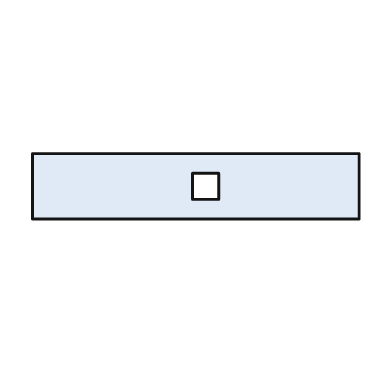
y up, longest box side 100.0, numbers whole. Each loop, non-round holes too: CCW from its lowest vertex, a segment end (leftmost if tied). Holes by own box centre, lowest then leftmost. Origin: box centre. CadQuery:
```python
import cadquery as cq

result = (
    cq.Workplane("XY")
    .moveTo(-50.0, -10.0)
    .lineTo(50.0, -10.0)
    .lineTo(50.0, 10.0)
    .lineTo(-50.0, 10.0)
    .close()
    .moveTo(-1.0, -4.0)
    .lineTo(7.0, -4.0)
    .lineTo(7.0, 4.0)
    .lineTo(-1.0, 4.0)
    .close()
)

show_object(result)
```